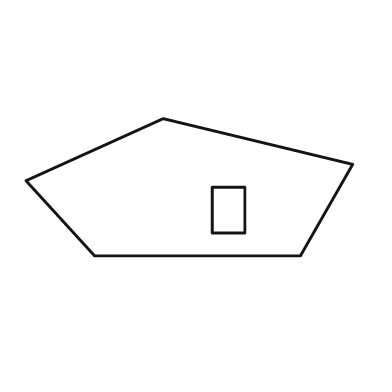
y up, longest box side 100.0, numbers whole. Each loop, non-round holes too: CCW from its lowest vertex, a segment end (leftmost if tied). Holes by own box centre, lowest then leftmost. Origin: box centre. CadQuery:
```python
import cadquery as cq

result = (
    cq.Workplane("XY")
    .moveTo(-29.0, -21.0)
    .lineTo(34.0, -21.0)
    .lineTo(50.0, 7.0)
    .lineTo(-8.0, 21.0)
    .lineTo(-50.0, 2.0)
    .close()
    .moveTo(7.0, -14.0)
    .lineTo(17.0, -14.0)
    .lineTo(17.0, 0.0)
    .lineTo(7.0, 0.0)
    .close()
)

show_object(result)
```